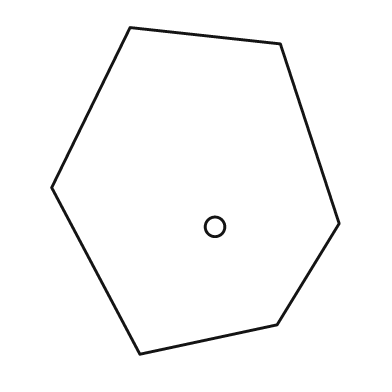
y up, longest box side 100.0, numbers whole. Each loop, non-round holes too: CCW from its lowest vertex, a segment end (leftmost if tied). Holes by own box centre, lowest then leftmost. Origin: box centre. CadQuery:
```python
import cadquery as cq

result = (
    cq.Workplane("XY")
    .moveTo(-17.0, -50.0)
    .lineTo(25.0, -41.0)
    .lineTo(44.0, -10.0)
    .lineTo(26.0, 45.0)
    .lineTo(-20.0, 50.0)
    .lineTo(-44.0, 1.0)
    .close()
    .moveTo(6.0, -11.0)
    .circle(3.0)
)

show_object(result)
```